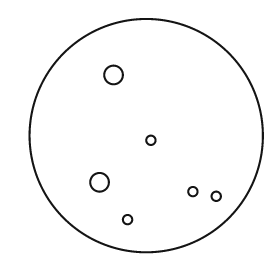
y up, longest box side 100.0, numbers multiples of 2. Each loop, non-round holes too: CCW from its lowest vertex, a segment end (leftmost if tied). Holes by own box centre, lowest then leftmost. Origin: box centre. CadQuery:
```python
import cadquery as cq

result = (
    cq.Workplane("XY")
    .moveTo(0.0, 0.0)
    .circle(50.0)
    .moveTo(-8.0, -36.0)
    .circle(2.0)
    .moveTo(30.0, -26.0)
    .circle(2.0)
    .moveTo(20.0, -24.0)
    .circle(2.0)
    .moveTo(-20.0, -20.0)
    .circle(4.0)
    .moveTo(2.0, -2.0)
    .circle(2.0)
    .moveTo(-14.0, 26.0)
    .circle(4.0)
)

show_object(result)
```